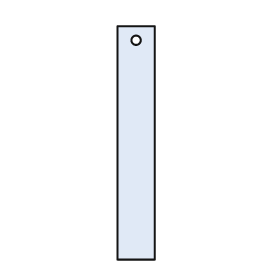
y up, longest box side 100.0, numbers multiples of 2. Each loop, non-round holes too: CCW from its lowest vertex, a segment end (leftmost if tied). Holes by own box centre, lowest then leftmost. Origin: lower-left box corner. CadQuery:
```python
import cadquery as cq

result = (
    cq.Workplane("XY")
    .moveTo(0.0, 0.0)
    .lineTo(16.0, 0.0)
    .lineTo(16.0, 100.0)
    .lineTo(0.0, 100.0)
    .close()
    .moveTo(8.0, 94.0)
    .circle(2.0)
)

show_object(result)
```